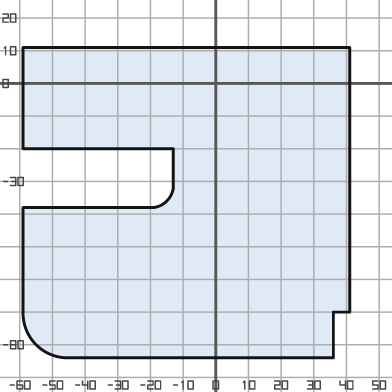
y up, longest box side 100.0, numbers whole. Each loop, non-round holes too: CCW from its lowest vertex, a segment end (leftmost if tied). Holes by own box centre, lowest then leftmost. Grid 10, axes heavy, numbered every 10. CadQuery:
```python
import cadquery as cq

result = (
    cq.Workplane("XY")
    .moveTo(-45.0, -84.0)
    .lineTo(36.0, -84.0)
    .lineTo(36.0, -70.0)
    .lineTo(41.0, -70.0)
    .lineTo(41.0, 11.0)
    .lineTo(-59.0, 11.0)
    .lineTo(-59.0, -20.0)
    .lineTo(-13.0, -20.0)
    .lineTo(-13.0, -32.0)
    .threePointArc((-15.0, -36.0), (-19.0, -38.0))
    .lineTo(-59.0, -38.0)
    .lineTo(-59.0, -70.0)
    .threePointArc((-55.0, -80.0), (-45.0, -84.0))
    .close()
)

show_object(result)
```